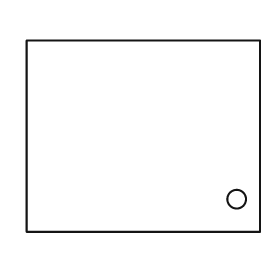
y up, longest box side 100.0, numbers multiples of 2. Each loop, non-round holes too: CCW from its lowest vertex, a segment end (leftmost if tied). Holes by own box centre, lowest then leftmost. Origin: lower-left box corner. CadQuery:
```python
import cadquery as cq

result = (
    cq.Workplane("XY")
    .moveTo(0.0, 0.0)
    .lineTo(100.0, 0.0)
    .lineTo(100.0, 82.0)
    .lineTo(0.0, 82.0)
    .close()
    .moveTo(90.0, 14.0)
    .circle(4.0)
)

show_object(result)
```